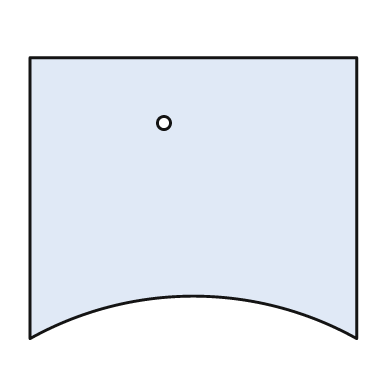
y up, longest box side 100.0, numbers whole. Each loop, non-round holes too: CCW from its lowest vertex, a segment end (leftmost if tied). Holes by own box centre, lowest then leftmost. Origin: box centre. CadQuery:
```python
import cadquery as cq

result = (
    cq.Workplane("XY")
    .moveTo(-50.0, -43.0)
    .threePointArc((0.0, -30.0), (50.0, -43.0))
    .lineTo(50.0, 43.0)
    .lineTo(-50.0, 43.0)
    .close()
    .moveTo(-9.0, 23.0)
    .circle(2.0)
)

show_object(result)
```